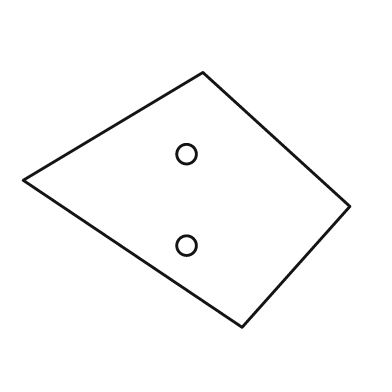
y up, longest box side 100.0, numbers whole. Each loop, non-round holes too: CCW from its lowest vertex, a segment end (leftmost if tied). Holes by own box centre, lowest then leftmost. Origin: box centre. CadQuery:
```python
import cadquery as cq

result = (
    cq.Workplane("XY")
    .moveTo(17.0, -39.0)
    .lineTo(50.0, -2.0)
    .lineTo(5.0, 39.0)
    .lineTo(-50.0, 6.0)
    .close()
    .moveTo(0.0, -14.0)
    .circle(3.0)
    .moveTo(0.0, 14.0)
    .circle(3.0)
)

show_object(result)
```